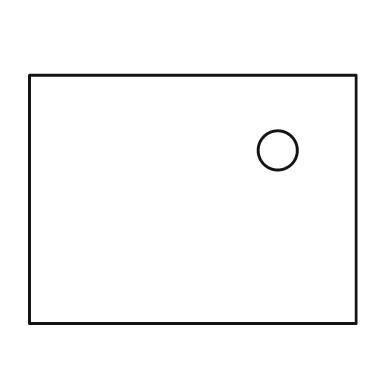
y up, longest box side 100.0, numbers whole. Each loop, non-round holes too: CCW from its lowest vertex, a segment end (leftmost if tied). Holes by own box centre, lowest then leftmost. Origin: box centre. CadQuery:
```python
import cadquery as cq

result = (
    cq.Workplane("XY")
    .moveTo(-50.0, -38.0)
    .lineTo(50.0, -38.0)
    .lineTo(50.0, 38.0)
    .lineTo(-50.0, 38.0)
    .close()
    .moveTo(26.0, 15.0)
    .circle(6.0)
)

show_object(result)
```